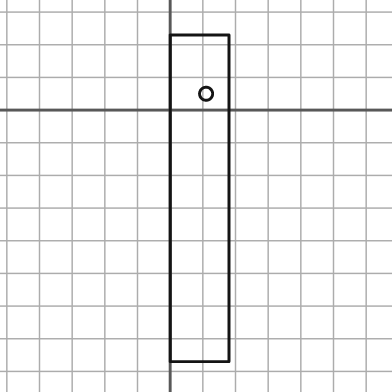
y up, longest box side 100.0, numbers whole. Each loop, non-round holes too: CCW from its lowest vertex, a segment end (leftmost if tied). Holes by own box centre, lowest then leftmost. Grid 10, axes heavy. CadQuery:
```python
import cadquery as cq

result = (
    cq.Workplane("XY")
    .moveTo(0.0, -77.0)
    .lineTo(18.0, -77.0)
    .lineTo(18.0, 23.0)
    .lineTo(0.0, 23.0)
    .close()
    .moveTo(11.0, 5.0)
    .circle(2.0)
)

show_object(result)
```